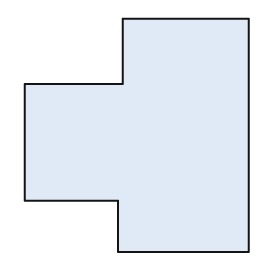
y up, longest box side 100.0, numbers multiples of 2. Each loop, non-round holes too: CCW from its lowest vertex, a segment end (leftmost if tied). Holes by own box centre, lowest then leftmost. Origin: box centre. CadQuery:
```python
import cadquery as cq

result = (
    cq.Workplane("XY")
    .moveTo(-8.0, -50.0)
    .lineTo(48.0, -50.0)
    .lineTo(48.0, 50.0)
    .lineTo(-6.0, 50.0)
    .lineTo(-6.0, 22.0)
    .lineTo(-48.0, 22.0)
    .lineTo(-48.0, -28.0)
    .lineTo(-8.0, -28.0)
    .close()
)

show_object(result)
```